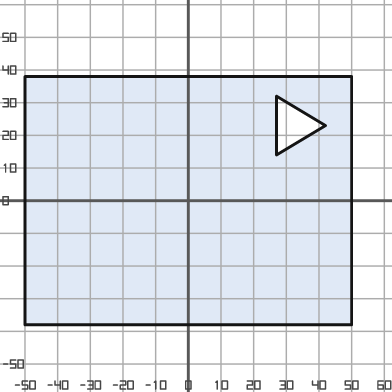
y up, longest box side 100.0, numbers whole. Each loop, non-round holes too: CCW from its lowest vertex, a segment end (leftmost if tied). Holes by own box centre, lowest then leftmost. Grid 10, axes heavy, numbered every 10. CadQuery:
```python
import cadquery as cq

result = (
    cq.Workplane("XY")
    .moveTo(-50.0, -38.0)
    .lineTo(50.0, -38.0)
    .lineTo(50.0, 38.0)
    .lineTo(-50.0, 38.0)
    .close()
    .moveTo(27.0, 14.0)
    .lineTo(42.0, 23.0)
    .lineTo(27.0, 32.0)
    .close()
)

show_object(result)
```